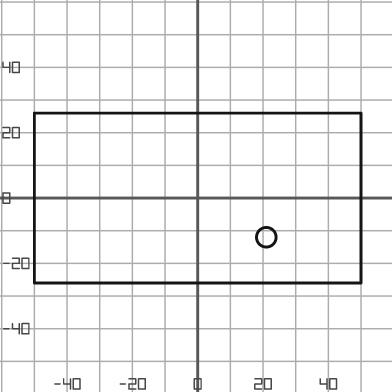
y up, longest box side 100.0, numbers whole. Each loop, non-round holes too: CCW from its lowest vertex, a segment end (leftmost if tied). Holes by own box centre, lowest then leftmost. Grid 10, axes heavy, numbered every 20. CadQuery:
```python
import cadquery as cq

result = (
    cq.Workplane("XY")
    .moveTo(-50.0, -26.0)
    .lineTo(50.0, -26.0)
    .lineTo(50.0, 26.0)
    .lineTo(-50.0, 26.0)
    .close()
    .moveTo(21.0, -12.0)
    .circle(3.0)
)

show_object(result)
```